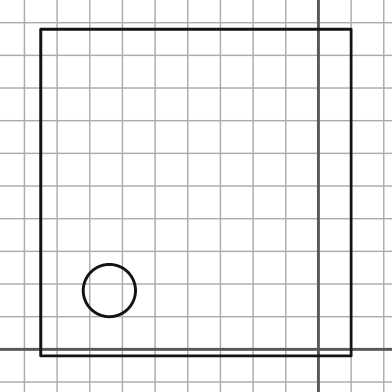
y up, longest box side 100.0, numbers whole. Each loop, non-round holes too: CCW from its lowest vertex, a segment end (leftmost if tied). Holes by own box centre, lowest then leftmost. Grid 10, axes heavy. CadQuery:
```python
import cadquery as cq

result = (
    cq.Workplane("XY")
    .moveTo(-85.0, -2.0)
    .lineTo(10.0, -2.0)
    .lineTo(10.0, 98.0)
    .lineTo(-85.0, 98.0)
    .close()
    .moveTo(-64.0, 18.0)
    .circle(8.0)
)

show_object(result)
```